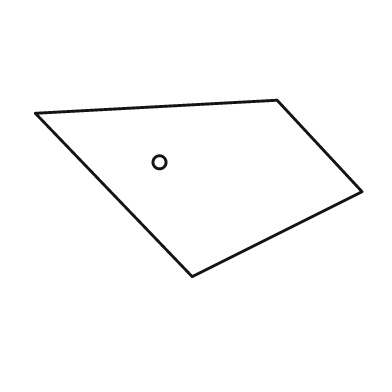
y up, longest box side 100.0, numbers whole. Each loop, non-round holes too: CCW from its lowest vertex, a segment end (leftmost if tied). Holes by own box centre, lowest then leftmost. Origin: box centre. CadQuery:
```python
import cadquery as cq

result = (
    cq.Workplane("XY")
    .moveTo(-2.0, -27.0)
    .lineTo(50.0, -1.0)
    .lineTo(24.0, 27.0)
    .lineTo(-50.0, 23.0)
    .close()
    .moveTo(-12.0, 8.0)
    .circle(2.0)
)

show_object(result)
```